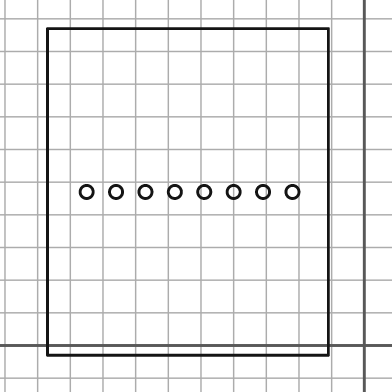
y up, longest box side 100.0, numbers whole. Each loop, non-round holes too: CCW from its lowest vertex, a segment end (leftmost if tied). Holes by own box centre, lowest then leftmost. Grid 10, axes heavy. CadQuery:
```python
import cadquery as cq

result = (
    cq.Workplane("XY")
    .moveTo(-97.0, -3.0)
    .lineTo(-11.0, -3.0)
    .lineTo(-11.0, 97.0)
    .lineTo(-97.0, 97.0)
    .close()
    .moveTo(-85.0, 47.0)
    .circle(2.0)
    .moveTo(-76.0, 47.0)
    .circle(2.0)
    .moveTo(-67.0, 47.0)
    .circle(2.0)
    .moveTo(-58.0, 47.0)
    .circle(2.0)
    .moveTo(-49.0, 47.0)
    .circle(2.0)
    .moveTo(-40.0, 47.0)
    .circle(2.0)
    .moveTo(-31.0, 47.0)
    .circle(2.0)
    .moveTo(-22.0, 47.0)
    .circle(2.0)
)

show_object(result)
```